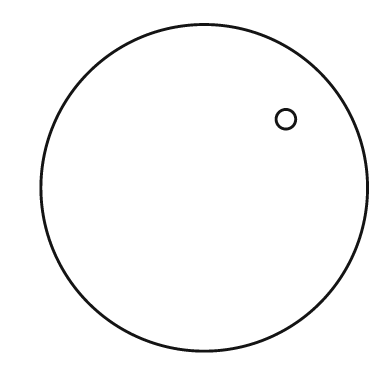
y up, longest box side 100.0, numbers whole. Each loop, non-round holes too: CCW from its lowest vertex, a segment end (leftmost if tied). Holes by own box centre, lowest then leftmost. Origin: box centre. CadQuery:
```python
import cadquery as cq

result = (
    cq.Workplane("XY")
    .moveTo(0.0, 0.0)
    .circle(50.0)
    .moveTo(25.0, 21.0)
    .circle(3.0)
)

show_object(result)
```